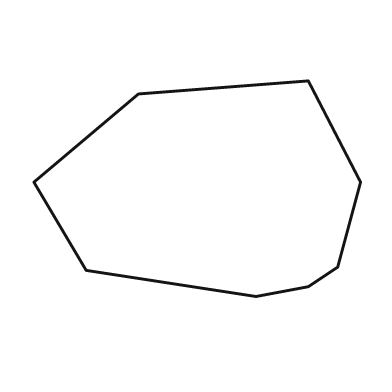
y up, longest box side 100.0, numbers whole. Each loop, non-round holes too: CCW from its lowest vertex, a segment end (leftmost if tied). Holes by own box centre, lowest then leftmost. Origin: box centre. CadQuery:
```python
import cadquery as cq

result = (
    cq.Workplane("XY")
    .moveTo(18.0, -33.0)
    .lineTo(34.0, -30.0)
    .lineTo(43.0, -24.0)
    .lineTo(50.0, 2.0)
    .lineTo(34.0, 33.0)
    .lineTo(-18.0, 29.0)
    .lineTo(-50.0, 2.0)
    .lineTo(-34.0, -25.0)
    .close()
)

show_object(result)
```